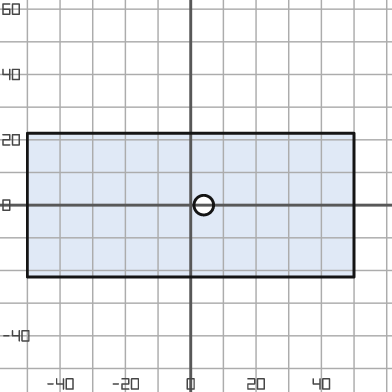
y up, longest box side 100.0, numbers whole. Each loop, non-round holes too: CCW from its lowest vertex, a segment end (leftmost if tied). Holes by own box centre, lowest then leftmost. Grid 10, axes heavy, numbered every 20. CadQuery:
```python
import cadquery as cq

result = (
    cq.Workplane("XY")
    .moveTo(-50.0, -22.0)
    .lineTo(50.0, -22.0)
    .lineTo(50.0, 22.0)
    .lineTo(-50.0, 22.0)
    .close()
    .moveTo(4.0, 0.0)
    .circle(3.0)
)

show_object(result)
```